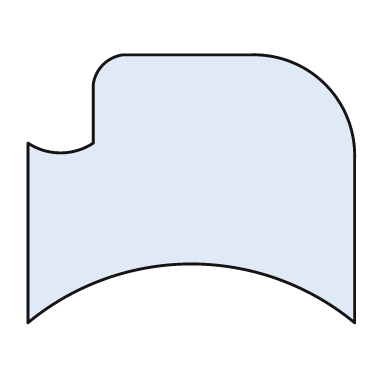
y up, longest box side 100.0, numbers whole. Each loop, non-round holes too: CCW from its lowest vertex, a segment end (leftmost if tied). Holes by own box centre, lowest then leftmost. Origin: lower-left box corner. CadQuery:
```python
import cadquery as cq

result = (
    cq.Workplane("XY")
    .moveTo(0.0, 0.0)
    .threePointArc((50.0, 18.0), (100.0, 0.0))
    .lineTo(100.0, 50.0)
    .threePointArc((91.0, 73.0), (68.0, 82.0))
    .lineTo(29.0, 82.0)
    .threePointArc((23.0, 79.0), (20.0, 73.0))
    .lineTo(20.0, 55.0)
    .threePointArc((10.0, 52.0), (0.0, 55.0))
    .close()
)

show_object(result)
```